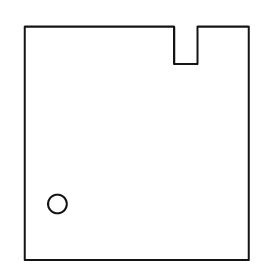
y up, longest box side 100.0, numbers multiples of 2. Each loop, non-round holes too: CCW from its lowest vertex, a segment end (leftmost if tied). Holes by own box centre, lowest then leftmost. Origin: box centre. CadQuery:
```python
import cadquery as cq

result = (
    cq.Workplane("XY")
    .moveTo(-48.0, -50.0)
    .lineTo(48.0, -50.0)
    .lineTo(48.0, 50.0)
    .lineTo(26.0, 50.0)
    .lineTo(26.0, 34.0)
    .lineTo(16.0, 34.0)
    .lineTo(16.0, 50.0)
    .lineTo(-48.0, 50.0)
    .close()
    .moveTo(-34.0, -26.0)
    .circle(4.0)
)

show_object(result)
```